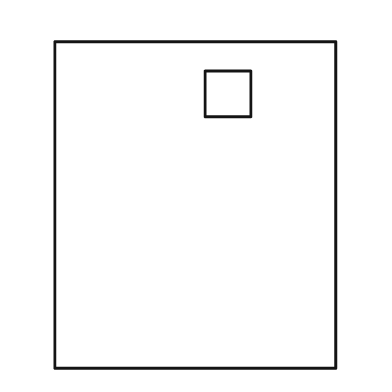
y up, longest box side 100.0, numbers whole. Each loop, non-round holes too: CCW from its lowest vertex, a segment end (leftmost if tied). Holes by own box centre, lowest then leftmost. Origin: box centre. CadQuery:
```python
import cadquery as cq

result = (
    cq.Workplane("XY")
    .moveTo(-43.0, -50.0)
    .lineTo(43.0, -50.0)
    .lineTo(43.0, 50.0)
    .lineTo(-43.0, 50.0)
    .close()
    .moveTo(3.0, 27.0)
    .lineTo(17.0, 27.0)
    .lineTo(17.0, 41.0)
    .lineTo(3.0, 41.0)
    .close()
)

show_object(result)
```